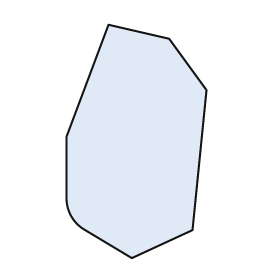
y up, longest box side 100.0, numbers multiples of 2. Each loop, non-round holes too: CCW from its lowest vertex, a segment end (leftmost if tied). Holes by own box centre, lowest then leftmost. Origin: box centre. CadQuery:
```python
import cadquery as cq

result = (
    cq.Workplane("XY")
    .moveTo(-2.0, -50.0)
    .lineTo(24.0, -38.0)
    .lineTo(30.0, 22.0)
    .lineTo(14.0, 44.0)
    .lineTo(-12.0, 50.0)
    .lineTo(-30.0, 2.0)
    .lineTo(-30.0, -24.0)
    .threePointArc((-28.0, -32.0), (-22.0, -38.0))
    .close()
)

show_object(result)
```